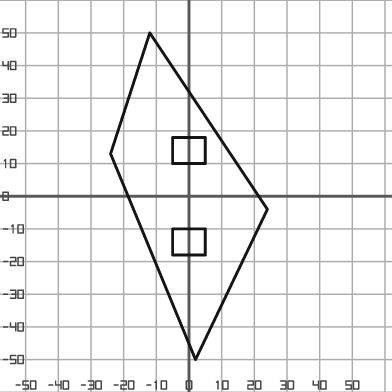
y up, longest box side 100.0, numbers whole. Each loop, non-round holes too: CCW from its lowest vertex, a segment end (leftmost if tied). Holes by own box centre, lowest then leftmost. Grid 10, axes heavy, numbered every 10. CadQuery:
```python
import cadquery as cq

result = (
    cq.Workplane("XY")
    .moveTo(2.0, -50.0)
    .lineTo(24.0, -4.0)
    .lineTo(-12.0, 50.0)
    .lineTo(-24.0, 13.0)
    .close()
    .moveTo(-5.0, -18.0)
    .lineTo(5.0, -18.0)
    .lineTo(5.0, -10.0)
    .lineTo(-5.0, -10.0)
    .close()
    .moveTo(-5.0, 10.0)
    .lineTo(5.0, 10.0)
    .lineTo(5.0, 18.0)
    .lineTo(-5.0, 18.0)
    .close()
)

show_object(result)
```